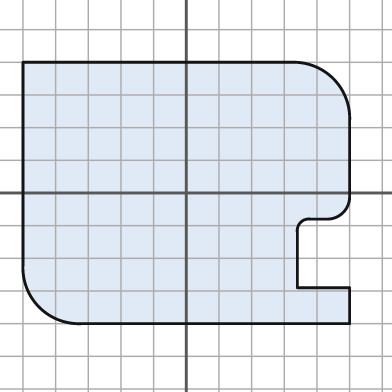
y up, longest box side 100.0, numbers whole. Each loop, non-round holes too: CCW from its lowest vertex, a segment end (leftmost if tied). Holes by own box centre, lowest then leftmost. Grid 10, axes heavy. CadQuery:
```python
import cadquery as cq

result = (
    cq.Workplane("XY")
    .moveTo(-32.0, -40.0)
    .lineTo(50.0, -40.0)
    .lineTo(50.0, -29.0)
    .lineTo(34.0, -29.0)
    .lineTo(34.0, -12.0)
    .threePointArc((35.0, -9.0), (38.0, -8.0))
    .lineTo(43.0, -8.0)
    .threePointArc((48.0, -6.0), (50.0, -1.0))
    .lineTo(50.0, 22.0)
    .threePointArc((45.0, 35.0), (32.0, 40.0))
    .lineTo(-50.0, 40.0)
    .lineTo(-50.0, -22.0)
    .threePointArc((-45.0, -35.0), (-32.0, -40.0))
    .close()
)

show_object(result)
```